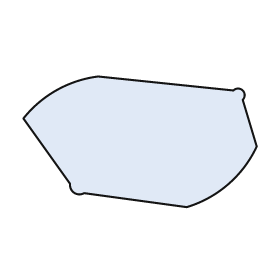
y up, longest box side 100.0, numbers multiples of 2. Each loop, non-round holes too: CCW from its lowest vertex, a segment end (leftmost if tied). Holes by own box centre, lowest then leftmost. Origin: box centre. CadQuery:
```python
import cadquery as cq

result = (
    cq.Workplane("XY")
    .moveTo(20.0, -28.0)
    .threePointArc((38.0, -18.0), (50.0, -2.0))
    .lineTo(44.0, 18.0)
    .threePointArc((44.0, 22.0), (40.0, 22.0))
    .lineTo(-18.0, 28.0)
    .threePointArc((-36.0, 22.0), (-50.0, 10.0))
    .lineTo(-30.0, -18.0)
    .threePointArc((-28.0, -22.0), (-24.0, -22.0))
    .close()
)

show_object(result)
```